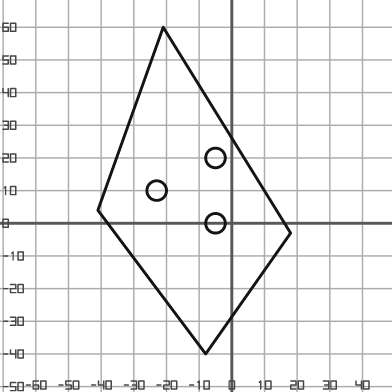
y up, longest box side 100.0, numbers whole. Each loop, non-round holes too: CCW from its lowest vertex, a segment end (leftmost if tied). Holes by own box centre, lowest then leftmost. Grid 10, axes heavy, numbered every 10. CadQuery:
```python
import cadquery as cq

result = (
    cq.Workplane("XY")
    .moveTo(-8.0, -40.0)
    .lineTo(18.0, -3.0)
    .lineTo(-21.0, 60.0)
    .lineTo(-41.0, 4.0)
    .close()
    .moveTo(-5.0, 0.0)
    .circle(3.0)
    .moveTo(-23.0, 10.0)
    .circle(3.0)
    .moveTo(-5.0, 20.0)
    .circle(3.0)
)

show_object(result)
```